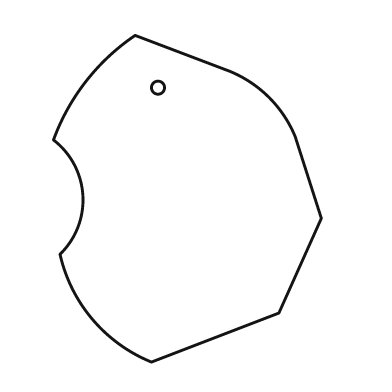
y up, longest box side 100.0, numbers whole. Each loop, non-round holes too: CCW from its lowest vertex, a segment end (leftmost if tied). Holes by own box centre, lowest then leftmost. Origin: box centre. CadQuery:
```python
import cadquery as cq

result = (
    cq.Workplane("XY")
    .moveTo(-11.0, -50.0)
    .lineTo(28.0, -35.0)
    .lineTo(41.0, -6.0)
    .lineTo(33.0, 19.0)
    .threePointArc((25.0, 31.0), (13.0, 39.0))
    .lineTo(-16.0, 50.0)
    .threePointArc((-31.0, 36.0), (-41.0, 18.0))
    .threePointArc((-32.0, 1.0), (-39.0, -17.0))
    .threePointArc((-29.0, -37.0), (-11.0, -50.0))
    .close()
    .moveTo(-9.0, 34.0)
    .circle(2.0)
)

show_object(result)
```